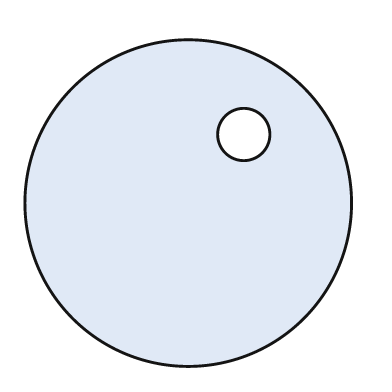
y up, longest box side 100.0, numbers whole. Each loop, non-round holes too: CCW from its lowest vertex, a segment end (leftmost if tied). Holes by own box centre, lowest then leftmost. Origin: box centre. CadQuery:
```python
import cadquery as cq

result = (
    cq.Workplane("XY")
    .moveTo(0.0, 0.0)
    .circle(50.0)
    .moveTo(17.0, 21.0)
    .circle(8.0)
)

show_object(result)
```